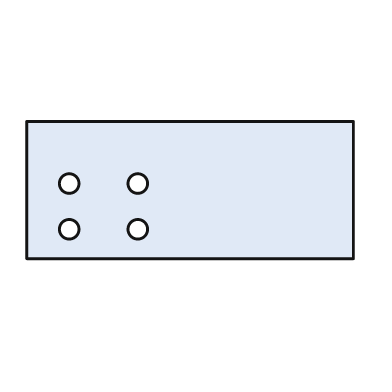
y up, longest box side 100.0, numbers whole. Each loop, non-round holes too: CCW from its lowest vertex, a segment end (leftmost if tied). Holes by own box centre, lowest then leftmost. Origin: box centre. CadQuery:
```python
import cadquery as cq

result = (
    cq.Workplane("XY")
    .moveTo(-50.0, -21.0)
    .lineTo(50.0, -21.0)
    .lineTo(50.0, 21.0)
    .lineTo(-50.0, 21.0)
    .close()
    .moveTo(-37.0, -12.0)
    .circle(3.0)
    .moveTo(-16.0, -12.0)
    .circle(3.0)
    .moveTo(-37.0, 2.0)
    .circle(3.0)
    .moveTo(-16.0, 2.0)
    .circle(3.0)
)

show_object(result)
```